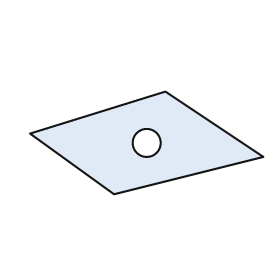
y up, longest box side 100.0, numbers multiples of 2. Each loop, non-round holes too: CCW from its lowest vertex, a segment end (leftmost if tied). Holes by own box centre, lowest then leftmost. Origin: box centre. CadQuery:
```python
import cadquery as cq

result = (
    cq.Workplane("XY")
    .moveTo(-14.0, -22.0)
    .lineTo(50.0, -6.0)
    .lineTo(8.0, 22.0)
    .lineTo(-50.0, 4.0)
    .close()
    .moveTo(0.0, 0.0)
    .circle(6.0)
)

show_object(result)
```